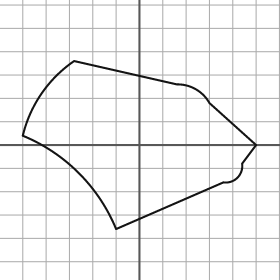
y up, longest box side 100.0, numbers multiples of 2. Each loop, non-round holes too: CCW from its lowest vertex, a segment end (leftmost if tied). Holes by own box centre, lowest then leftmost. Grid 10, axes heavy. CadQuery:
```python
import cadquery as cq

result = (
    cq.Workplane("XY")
    .moveTo(-10.0, -36.0)
    .lineTo(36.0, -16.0)
    .threePointArc((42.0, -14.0), (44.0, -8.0))
    .lineTo(50.0, 0.0)
    .lineTo(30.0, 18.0)
    .threePointArc((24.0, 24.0), (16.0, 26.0))
    .lineTo(-28.0, 36.0)
    .threePointArc((-42.0, 22.0), (-50.0, 4.0))
    .threePointArc((-26.0, -12.0), (-10.0, -36.0))
    .close()
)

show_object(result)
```